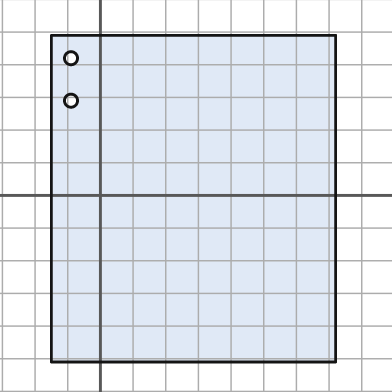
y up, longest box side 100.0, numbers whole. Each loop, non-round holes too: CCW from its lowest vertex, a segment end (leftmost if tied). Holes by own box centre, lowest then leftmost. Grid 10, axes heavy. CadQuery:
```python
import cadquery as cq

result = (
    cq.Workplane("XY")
    .moveTo(-15.0, -51.0)
    .lineTo(72.0, -51.0)
    .lineTo(72.0, 49.0)
    .lineTo(-15.0, 49.0)
    .close()
    .moveTo(-9.0, 29.0)
    .circle(2.0)
    .moveTo(-9.0, 42.0)
    .circle(2.0)
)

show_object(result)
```